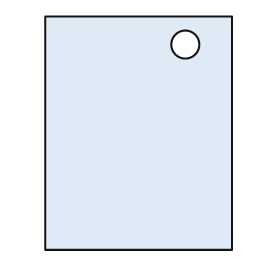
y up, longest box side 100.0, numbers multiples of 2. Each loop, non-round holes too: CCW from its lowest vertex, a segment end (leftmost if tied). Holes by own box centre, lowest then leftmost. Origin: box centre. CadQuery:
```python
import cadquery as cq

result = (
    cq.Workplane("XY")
    .moveTo(-40.0, -50.0)
    .lineTo(40.0, -50.0)
    .lineTo(40.0, 50.0)
    .lineTo(-40.0, 50.0)
    .close()
    .moveTo(20.0, 38.0)
    .circle(6.0)
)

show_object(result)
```